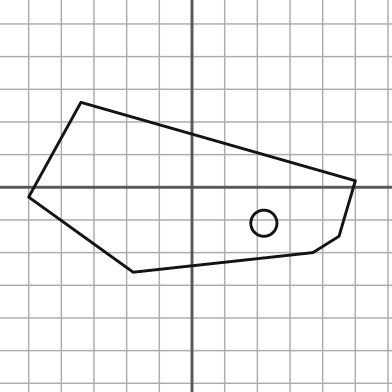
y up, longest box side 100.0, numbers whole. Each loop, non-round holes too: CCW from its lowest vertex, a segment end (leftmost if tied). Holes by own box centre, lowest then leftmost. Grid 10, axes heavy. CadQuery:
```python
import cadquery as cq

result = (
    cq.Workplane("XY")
    .moveTo(-18.0, -26.0)
    .lineTo(37.0, -20.0)
    .lineTo(45.0, -15.0)
    .lineTo(50.0, 2.0)
    .lineTo(-34.0, 26.0)
    .lineTo(-50.0, -3.0)
    .close()
    .moveTo(22.0, -11.0)
    .circle(4.0)
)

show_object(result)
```